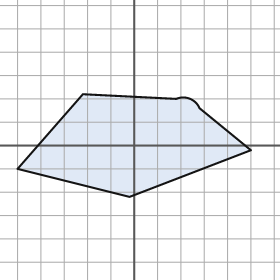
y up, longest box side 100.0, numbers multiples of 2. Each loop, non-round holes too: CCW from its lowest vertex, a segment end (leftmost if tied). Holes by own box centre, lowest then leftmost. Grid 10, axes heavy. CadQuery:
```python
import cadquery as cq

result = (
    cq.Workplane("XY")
    .moveTo(-2.0, -22.0)
    .lineTo(50.0, -2.0)
    .lineTo(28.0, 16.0)
    .threePointArc((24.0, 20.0), (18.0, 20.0))
    .lineTo(-22.0, 22.0)
    .lineTo(-50.0, -10.0)
    .close()
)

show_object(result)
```